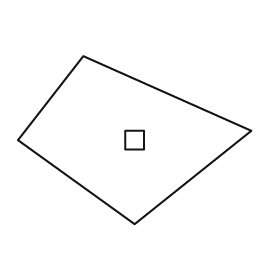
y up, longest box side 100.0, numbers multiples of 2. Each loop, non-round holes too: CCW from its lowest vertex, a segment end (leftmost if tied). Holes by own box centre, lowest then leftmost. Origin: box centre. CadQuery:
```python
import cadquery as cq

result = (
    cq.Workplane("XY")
    .moveTo(0.0, -36.0)
    .lineTo(50.0, 4.0)
    .lineTo(-22.0, 36.0)
    .lineTo(-50.0, 0.0)
    .close()
    .moveTo(-4.0, -4.0)
    .lineTo(4.0, -4.0)
    .lineTo(4.0, 4.0)
    .lineTo(-4.0, 4.0)
    .close()
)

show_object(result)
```